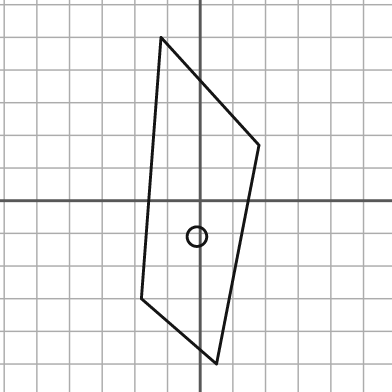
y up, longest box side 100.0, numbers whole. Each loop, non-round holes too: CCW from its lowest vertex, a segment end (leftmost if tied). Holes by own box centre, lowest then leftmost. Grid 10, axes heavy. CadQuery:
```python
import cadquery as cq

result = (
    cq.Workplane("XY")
    .moveTo(5.0, -50.0)
    .lineTo(18.0, 17.0)
    .lineTo(-12.0, 50.0)
    .lineTo(-18.0, -30.0)
    .close()
    .moveTo(-1.0, -11.0)
    .circle(3.0)
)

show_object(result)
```